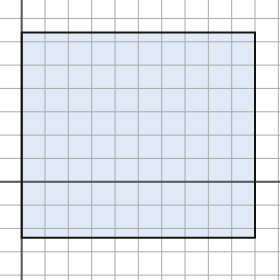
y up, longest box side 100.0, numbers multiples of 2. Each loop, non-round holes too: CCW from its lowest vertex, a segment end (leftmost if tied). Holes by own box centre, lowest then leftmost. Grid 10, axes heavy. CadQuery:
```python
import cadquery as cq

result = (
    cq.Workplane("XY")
    .moveTo(0.0, -24.0)
    .lineTo(100.0, -24.0)
    .lineTo(100.0, 64.0)
    .lineTo(0.0, 64.0)
    .close()
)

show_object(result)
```